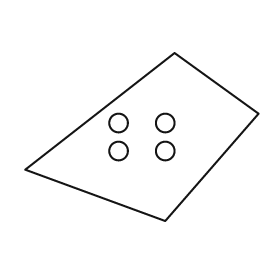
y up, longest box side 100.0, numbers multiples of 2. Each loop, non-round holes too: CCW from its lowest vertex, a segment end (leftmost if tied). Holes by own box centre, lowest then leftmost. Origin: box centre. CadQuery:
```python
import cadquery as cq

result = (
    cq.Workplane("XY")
    .moveTo(10.0, -36.0)
    .lineTo(50.0, 10.0)
    .lineTo(14.0, 36.0)
    .lineTo(-50.0, -14.0)
    .close()
    .moveTo(-10.0, -6.0)
    .circle(4.0)
    .moveTo(10.0, -6.0)
    .circle(4.0)
    .moveTo(-10.0, 6.0)
    .circle(4.0)
    .moveTo(10.0, 6.0)
    .circle(4.0)
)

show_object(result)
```